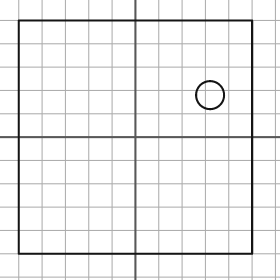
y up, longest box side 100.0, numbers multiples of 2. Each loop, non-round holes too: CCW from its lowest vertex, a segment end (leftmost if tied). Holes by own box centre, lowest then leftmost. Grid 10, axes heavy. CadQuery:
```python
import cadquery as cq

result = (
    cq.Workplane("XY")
    .moveTo(-50.0, -50.0)
    .lineTo(50.0, -50.0)
    .lineTo(50.0, 50.0)
    .lineTo(-50.0, 50.0)
    .close()
    .moveTo(32.0, 18.0)
    .circle(6.0)
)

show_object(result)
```